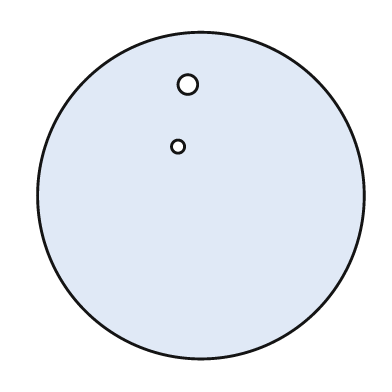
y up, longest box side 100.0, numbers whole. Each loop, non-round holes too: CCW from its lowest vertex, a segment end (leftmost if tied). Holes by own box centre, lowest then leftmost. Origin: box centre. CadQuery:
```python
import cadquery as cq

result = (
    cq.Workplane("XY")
    .moveTo(0.0, 0.0)
    .circle(50.0)
    .moveTo(-7.0, 15.0)
    .circle(2.0)
    .moveTo(-4.0, 34.0)
    .circle(3.0)
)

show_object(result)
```